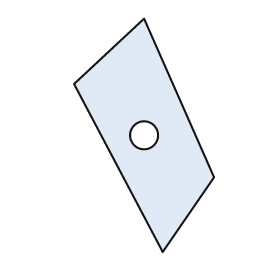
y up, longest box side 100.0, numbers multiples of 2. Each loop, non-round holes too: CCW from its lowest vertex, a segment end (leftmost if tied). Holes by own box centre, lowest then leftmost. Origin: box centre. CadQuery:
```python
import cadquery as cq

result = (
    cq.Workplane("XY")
    .moveTo(8.0, -50.0)
    .lineTo(30.0, -18.0)
    .lineTo(0.0, 50.0)
    .lineTo(-30.0, 22.0)
    .close()
    .moveTo(0.0, 0.0)
    .circle(6.0)
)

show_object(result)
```